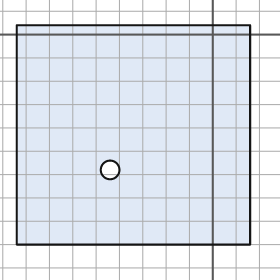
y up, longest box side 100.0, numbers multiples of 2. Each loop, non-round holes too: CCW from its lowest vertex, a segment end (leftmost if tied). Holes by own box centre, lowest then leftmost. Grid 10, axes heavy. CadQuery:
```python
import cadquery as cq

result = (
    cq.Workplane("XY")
    .moveTo(-84.0, -90.0)
    .lineTo(16.0, -90.0)
    .lineTo(16.0, 4.0)
    .lineTo(-84.0, 4.0)
    .close()
    .moveTo(-44.0, -58.0)
    .circle(4.0)
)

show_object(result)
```